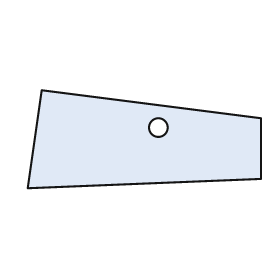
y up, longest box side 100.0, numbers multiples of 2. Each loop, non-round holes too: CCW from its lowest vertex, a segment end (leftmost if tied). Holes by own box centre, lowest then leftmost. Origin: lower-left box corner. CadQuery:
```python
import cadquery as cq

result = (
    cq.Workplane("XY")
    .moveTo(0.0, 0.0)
    .lineTo(100.0, 4.0)
    .lineTo(100.0, 30.0)
    .lineTo(6.0, 42.0)
    .close()
    .moveTo(56.0, 26.0)
    .circle(4.0)
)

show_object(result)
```